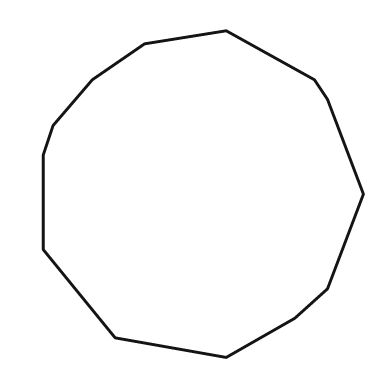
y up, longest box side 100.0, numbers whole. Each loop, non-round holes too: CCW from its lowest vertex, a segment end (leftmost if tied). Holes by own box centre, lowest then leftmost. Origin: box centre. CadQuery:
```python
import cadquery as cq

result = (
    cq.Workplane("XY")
    .moveTo(7.0, -50.0)
    .lineTo(28.0, -38.0)
    .lineTo(38.0, -29.0)
    .lineTo(49.0, 0.0)
    .lineTo(38.0, 29.0)
    .lineTo(34.0, 35.0)
    .lineTo(7.0, 50.0)
    .lineTo(-18.0, 46.0)
    .lineTo(-34.0, 35.0)
    .lineTo(-46.0, 21.0)
    .lineTo(-49.0, 12.0)
    .lineTo(-49.0, -17.0)
    .lineTo(-27.0, -44.0)
    .close()
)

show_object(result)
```